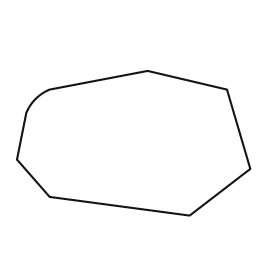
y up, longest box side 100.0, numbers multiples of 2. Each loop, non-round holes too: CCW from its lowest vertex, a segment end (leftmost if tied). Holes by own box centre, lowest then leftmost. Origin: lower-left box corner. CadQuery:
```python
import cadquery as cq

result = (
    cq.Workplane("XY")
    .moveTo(74.0, 0.0)
    .lineTo(100.0, 20.0)
    .lineTo(90.0, 54.0)
    .lineTo(56.0, 62.0)
    .lineTo(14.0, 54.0)
    .threePointArc((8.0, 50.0), (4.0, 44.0))
    .lineTo(0.0, 24.0)
    .lineTo(14.0, 8.0)
    .close()
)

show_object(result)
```